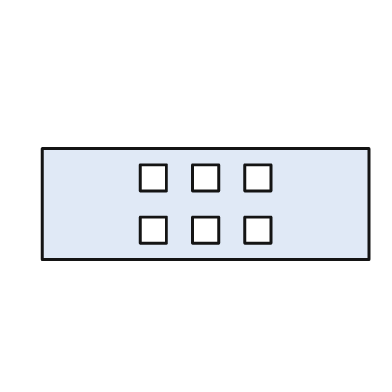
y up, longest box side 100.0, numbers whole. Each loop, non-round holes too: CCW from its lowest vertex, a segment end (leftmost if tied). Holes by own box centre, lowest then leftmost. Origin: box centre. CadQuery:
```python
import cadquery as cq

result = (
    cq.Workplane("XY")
    .moveTo(-50.0, -17.0)
    .lineTo(50.0, -17.0)
    .lineTo(50.0, 17.0)
    .lineTo(-50.0, 17.0)
    .close()
    .moveTo(-20.0, -12.0)
    .lineTo(-12.0, -12.0)
    .lineTo(-12.0, -4.0)
    .lineTo(-20.0, -4.0)
    .close()
    .moveTo(-4.0, -12.0)
    .lineTo(4.0, -12.0)
    .lineTo(4.0, -4.0)
    .lineTo(-4.0, -4.0)
    .close()
    .moveTo(12.0, -12.0)
    .lineTo(20.0, -12.0)
    .lineTo(20.0, -4.0)
    .lineTo(12.0, -4.0)
    .close()
    .moveTo(-20.0, 4.0)
    .lineTo(-12.0, 4.0)
    .lineTo(-12.0, 12.0)
    .lineTo(-20.0, 12.0)
    .close()
    .moveTo(-4.0, 4.0)
    .lineTo(4.0, 4.0)
    .lineTo(4.0, 12.0)
    .lineTo(-4.0, 12.0)
    .close()
    .moveTo(12.0, 4.0)
    .lineTo(20.0, 4.0)
    .lineTo(20.0, 12.0)
    .lineTo(12.0, 12.0)
    .close()
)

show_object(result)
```